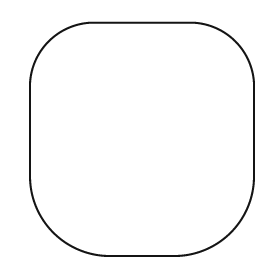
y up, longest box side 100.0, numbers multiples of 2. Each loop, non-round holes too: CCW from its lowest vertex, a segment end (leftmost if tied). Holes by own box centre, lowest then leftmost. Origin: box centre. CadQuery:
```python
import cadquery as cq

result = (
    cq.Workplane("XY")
    .moveTo(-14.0, -50.0)
    .lineTo(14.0, -50.0)
    .threePointArc((38.0, -40.0), (48.0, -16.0))
    .lineTo(48.0, 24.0)
    .threePointArc((40.0, 42.0), (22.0, 50.0))
    .lineTo(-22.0, 50.0)
    .threePointArc((-40.0, 42.0), (-48.0, 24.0))
    .lineTo(-48.0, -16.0)
    .threePointArc((-38.0, -40.0), (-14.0, -50.0))
    .close()
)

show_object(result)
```